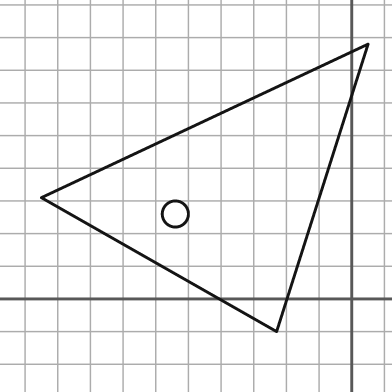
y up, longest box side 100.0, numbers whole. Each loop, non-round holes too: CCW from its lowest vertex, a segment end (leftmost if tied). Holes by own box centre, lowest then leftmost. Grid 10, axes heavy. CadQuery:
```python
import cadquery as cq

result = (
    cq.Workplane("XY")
    .moveTo(-23.0, -10.0)
    .lineTo(5.0, 78.0)
    .lineTo(-95.0, 31.0)
    .close()
    .moveTo(-54.0, 26.0)
    .circle(4.0)
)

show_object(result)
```